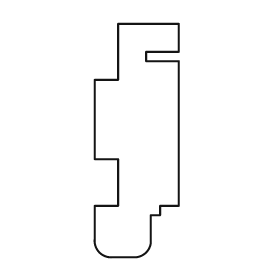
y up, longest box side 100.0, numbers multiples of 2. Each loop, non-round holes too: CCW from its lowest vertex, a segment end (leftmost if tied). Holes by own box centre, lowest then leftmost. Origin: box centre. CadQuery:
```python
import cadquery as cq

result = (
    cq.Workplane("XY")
    .moveTo(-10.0, -50.0)
    .lineTo(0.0, -50.0)
    .threePointArc((4.0, -48.0), (6.0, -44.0))
    .lineTo(6.0, -32.0)
    .lineTo(10.0, -32.0)
    .lineTo(10.0, -28.0)
    .lineTo(18.0, -28.0)
    .lineTo(18.0, 34.0)
    .lineTo(4.0, 34.0)
    .lineTo(4.0, 38.0)
    .lineTo(18.0, 38.0)
    .lineTo(18.0, 50.0)
    .lineTo(-8.0, 50.0)
    .lineTo(-8.0, 26.0)
    .lineTo(-18.0, 26.0)
    .lineTo(-18.0, -8.0)
    .lineTo(-8.0, -8.0)
    .lineTo(-8.0, -28.0)
    .lineTo(-18.0, -28.0)
    .lineTo(-18.0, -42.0)
    .threePointArc((-16.0, -48.0), (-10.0, -50.0))
    .close()
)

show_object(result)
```